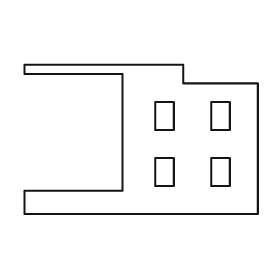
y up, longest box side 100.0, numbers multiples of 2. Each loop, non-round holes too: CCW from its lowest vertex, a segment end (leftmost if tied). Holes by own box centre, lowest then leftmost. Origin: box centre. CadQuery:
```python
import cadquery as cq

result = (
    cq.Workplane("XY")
    .moveTo(-50.0, -32.0)
    .lineTo(50.0, -32.0)
    .lineTo(50.0, 24.0)
    .lineTo(18.0, 24.0)
    .lineTo(18.0, 32.0)
    .lineTo(-50.0, 32.0)
    .lineTo(-50.0, 28.0)
    .lineTo(-8.0, 28.0)
    .lineTo(-8.0, -22.0)
    .lineTo(-50.0, -22.0)
    .close()
    .moveTo(6.0, -20.0)
    .lineTo(14.0, -20.0)
    .lineTo(14.0, -8.0)
    .lineTo(6.0, -8.0)
    .close()
    .moveTo(30.0, -20.0)
    .lineTo(38.0, -20.0)
    .lineTo(38.0, -8.0)
    .lineTo(30.0, -8.0)
    .close()
    .moveTo(6.0, 4.0)
    .lineTo(14.0, 4.0)
    .lineTo(14.0, 16.0)
    .lineTo(6.0, 16.0)
    .close()
    .moveTo(30.0, 4.0)
    .lineTo(38.0, 4.0)
    .lineTo(38.0, 16.0)
    .lineTo(30.0, 16.0)
    .close()
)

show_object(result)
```